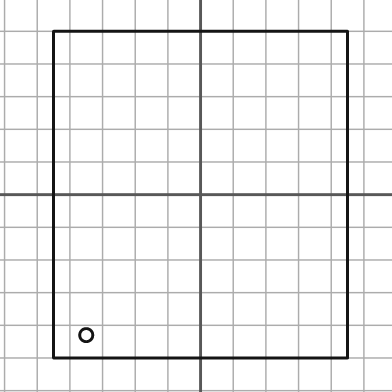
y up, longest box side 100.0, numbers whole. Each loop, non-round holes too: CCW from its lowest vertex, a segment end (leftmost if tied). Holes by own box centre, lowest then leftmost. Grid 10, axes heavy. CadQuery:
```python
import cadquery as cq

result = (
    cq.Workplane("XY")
    .moveTo(-45.0, -50.0)
    .lineTo(45.0, -50.0)
    .lineTo(45.0, 50.0)
    .lineTo(-45.0, 50.0)
    .close()
    .moveTo(-35.0, -43.0)
    .circle(2.0)
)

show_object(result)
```